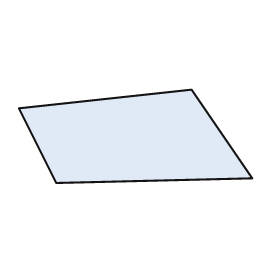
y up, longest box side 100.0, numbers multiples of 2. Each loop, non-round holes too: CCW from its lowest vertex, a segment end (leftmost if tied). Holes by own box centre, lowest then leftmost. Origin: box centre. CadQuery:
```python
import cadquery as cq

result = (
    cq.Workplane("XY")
    .moveTo(-34.0, -20.0)
    .lineTo(50.0, -18.0)
    .lineTo(24.0, 20.0)
    .lineTo(-50.0, 12.0)
    .close()
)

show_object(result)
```